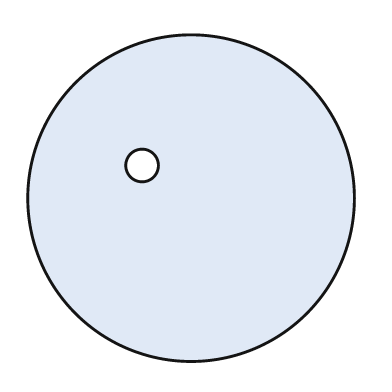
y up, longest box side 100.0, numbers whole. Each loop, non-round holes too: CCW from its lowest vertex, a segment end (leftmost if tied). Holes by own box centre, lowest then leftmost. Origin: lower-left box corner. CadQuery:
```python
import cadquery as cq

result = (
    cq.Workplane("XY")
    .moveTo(50.0, 50.0)
    .circle(50.0)
    .moveTo(35.0, 60.0)
    .circle(5.0)
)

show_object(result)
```